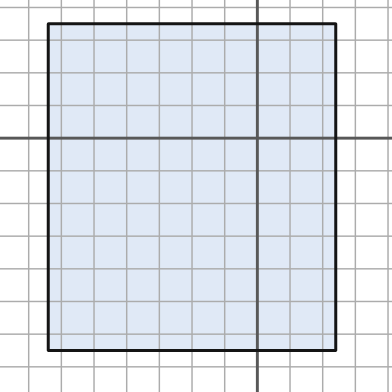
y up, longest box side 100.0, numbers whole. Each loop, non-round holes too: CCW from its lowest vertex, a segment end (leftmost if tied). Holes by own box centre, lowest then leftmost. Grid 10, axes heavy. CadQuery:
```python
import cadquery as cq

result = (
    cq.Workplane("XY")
    .moveTo(-64.0, -65.0)
    .lineTo(24.0, -65.0)
    .lineTo(24.0, 35.0)
    .lineTo(-64.0, 35.0)
    .close()
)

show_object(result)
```